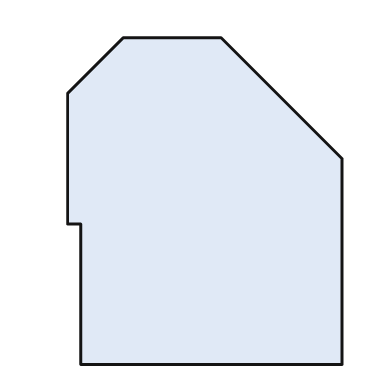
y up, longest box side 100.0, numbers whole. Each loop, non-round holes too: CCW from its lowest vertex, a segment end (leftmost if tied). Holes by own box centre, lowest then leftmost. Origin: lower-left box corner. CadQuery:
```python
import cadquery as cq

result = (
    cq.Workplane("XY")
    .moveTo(4.0, 0.0)
    .lineTo(84.0, 0.0)
    .lineTo(84.0, 63.0)
    .lineTo(47.0, 100.0)
    .lineTo(17.0, 100.0)
    .lineTo(0.0, 83.0)
    .lineTo(0.0, 43.0)
    .lineTo(4.0, 43.0)
    .close()
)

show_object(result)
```